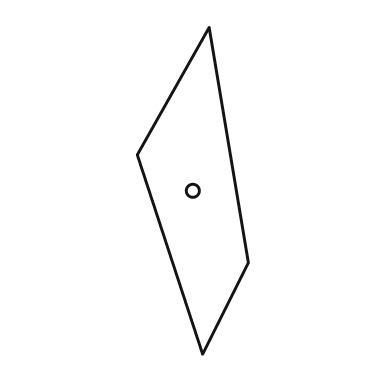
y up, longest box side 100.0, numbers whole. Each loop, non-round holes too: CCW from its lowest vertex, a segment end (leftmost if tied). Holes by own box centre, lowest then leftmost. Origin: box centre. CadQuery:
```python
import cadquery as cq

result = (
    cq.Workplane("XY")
    .moveTo(3.0, -50.0)
    .lineTo(17.0, -22.0)
    .lineTo(5.0, 50.0)
    .lineTo(-17.0, 11.0)
    .close()
    .moveTo(0.0, 0.0)
    .circle(2.0)
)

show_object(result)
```